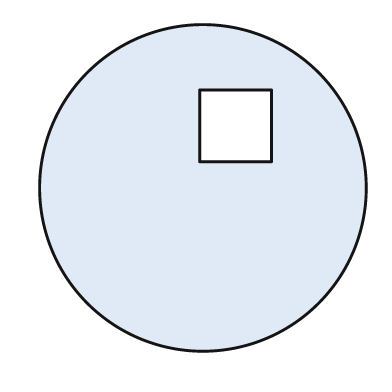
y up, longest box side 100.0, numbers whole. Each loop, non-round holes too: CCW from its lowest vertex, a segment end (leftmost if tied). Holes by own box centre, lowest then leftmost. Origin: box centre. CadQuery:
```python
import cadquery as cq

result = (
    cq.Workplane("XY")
    .moveTo(0.0, 0.0)
    .circle(50.0)
    .moveTo(-1.0, 8.0)
    .lineTo(21.0, 8.0)
    .lineTo(21.0, 30.0)
    .lineTo(-1.0, 30.0)
    .close()
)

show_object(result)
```